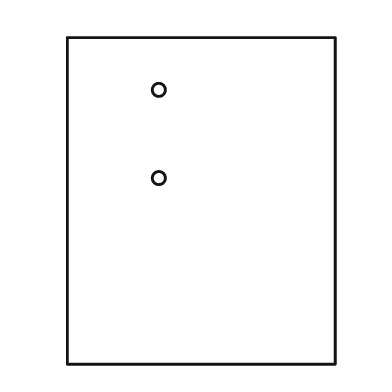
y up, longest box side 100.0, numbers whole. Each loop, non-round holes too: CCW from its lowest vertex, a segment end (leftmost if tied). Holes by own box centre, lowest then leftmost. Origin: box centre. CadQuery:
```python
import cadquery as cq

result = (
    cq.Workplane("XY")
    .moveTo(-41.0, -50.0)
    .lineTo(41.0, -50.0)
    .lineTo(41.0, 50.0)
    .lineTo(-41.0, 50.0)
    .close()
    .moveTo(-13.0, 7.0)
    .circle(2.0)
    .moveTo(-13.0, 34.0)
    .circle(2.0)
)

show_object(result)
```